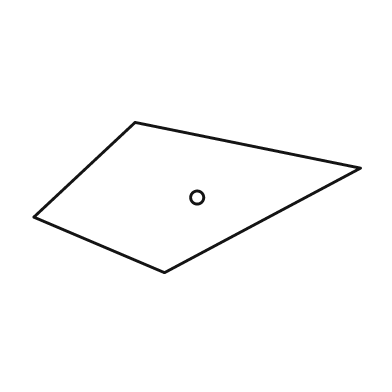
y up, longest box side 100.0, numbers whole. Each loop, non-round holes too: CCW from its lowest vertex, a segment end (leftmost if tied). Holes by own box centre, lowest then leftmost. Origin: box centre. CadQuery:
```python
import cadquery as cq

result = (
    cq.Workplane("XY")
    .moveTo(-10.0, -23.0)
    .lineTo(50.0, 9.0)
    .lineTo(-19.0, 23.0)
    .lineTo(-50.0, -6.0)
    .close()
    .moveTo(0.0, 0.0)
    .circle(2.0)
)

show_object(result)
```